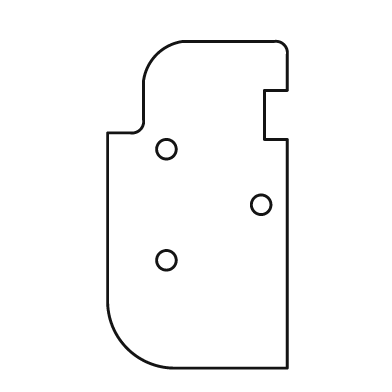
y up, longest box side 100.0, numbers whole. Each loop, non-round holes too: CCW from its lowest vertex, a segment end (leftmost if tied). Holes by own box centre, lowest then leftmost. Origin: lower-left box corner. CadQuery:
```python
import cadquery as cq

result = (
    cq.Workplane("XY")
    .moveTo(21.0, 0.0)
    .lineTo(55.0, 0.0)
    .lineTo(55.0, 70.0)
    .lineTo(48.0, 70.0)
    .lineTo(48.0, 85.0)
    .lineTo(55.0, 85.0)
    .lineTo(55.0, 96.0)
    .threePointArc((54.0, 99.0), (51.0, 100.0))
    .lineTo(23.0, 100.0)
    .threePointArc((15.0, 96.0), (11.0, 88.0))
    .lineTo(11.0, 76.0)
    .threePointArc((10.0, 73.0), (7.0, 72.0))
    .lineTo(0.0, 72.0)
    .lineTo(0.0, 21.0)
    .threePointArc((6.0, 6.0), (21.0, 0.0))
    .close()
    .moveTo(18.0, 33.0)
    .circle(3.0)
    .moveTo(47.0, 50.0)
    .circle(3.0)
    .moveTo(18.0, 67.0)
    .circle(3.0)
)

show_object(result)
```